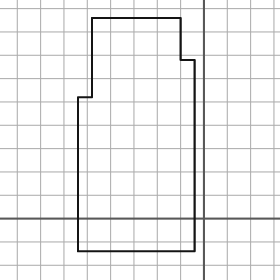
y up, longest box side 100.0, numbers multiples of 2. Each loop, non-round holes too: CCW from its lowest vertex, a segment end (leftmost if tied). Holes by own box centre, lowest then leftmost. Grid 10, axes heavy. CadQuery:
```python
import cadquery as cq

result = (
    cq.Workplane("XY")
    .moveTo(-54.0, -14.0)
    .lineTo(-4.0, -14.0)
    .lineTo(-4.0, 68.0)
    .lineTo(-10.0, 68.0)
    .lineTo(-10.0, 86.0)
    .lineTo(-48.0, 86.0)
    .lineTo(-48.0, 52.0)
    .lineTo(-54.0, 52.0)
    .close()
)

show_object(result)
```